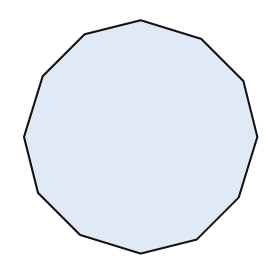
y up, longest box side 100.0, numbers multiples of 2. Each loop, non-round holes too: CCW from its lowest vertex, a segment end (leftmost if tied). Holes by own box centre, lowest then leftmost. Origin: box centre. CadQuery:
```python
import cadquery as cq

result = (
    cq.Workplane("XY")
    .moveTo(0.0, -50.0)
    .lineTo(24.0, -44.0)
    .lineTo(42.0, -26.0)
    .lineTo(50.0, 0.0)
    .lineTo(44.0, 24.0)
    .lineTo(26.0, 42.0)
    .lineTo(0.0, 50.0)
    .lineTo(-24.0, 44.0)
    .lineTo(-42.0, 26.0)
    .lineTo(-50.0, 0.0)
    .lineTo(-44.0, -24.0)
    .lineTo(-26.0, -42.0)
    .close()
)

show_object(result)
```